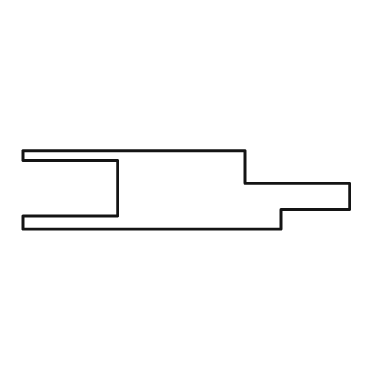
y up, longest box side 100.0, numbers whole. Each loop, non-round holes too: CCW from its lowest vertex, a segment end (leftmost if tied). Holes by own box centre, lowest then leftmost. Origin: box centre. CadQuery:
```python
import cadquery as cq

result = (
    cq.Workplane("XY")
    .moveTo(-50.0, -12.0)
    .lineTo(29.0, -12.0)
    .lineTo(29.0, -6.0)
    .lineTo(50.0, -6.0)
    .lineTo(50.0, 2.0)
    .lineTo(18.0, 2.0)
    .lineTo(18.0, 12.0)
    .lineTo(-50.0, 12.0)
    .lineTo(-50.0, 9.0)
    .lineTo(-21.0, 9.0)
    .lineTo(-21.0, -8.0)
    .lineTo(-50.0, -8.0)
    .close()
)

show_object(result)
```